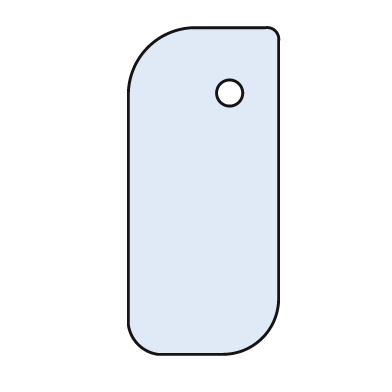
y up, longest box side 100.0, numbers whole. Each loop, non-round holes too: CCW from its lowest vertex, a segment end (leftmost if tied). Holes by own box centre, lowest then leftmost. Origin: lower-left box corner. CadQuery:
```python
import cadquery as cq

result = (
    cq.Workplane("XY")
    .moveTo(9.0, 0.0)
    .lineTo(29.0, 0.0)
    .threePointArc((41.0, 5.0), (46.0, 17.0))
    .lineTo(46.0, 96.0)
    .threePointArc((45.0, 99.0), (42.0, 100.0))
    .lineTo(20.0, 100.0)
    .threePointArc((6.0, 94.0), (0.0, 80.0))
    .lineTo(0.0, 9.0)
    .threePointArc((3.0, 3.0), (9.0, 0.0))
    .close()
    .moveTo(31.0, 80.0)
    .circle(4.0)
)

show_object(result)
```